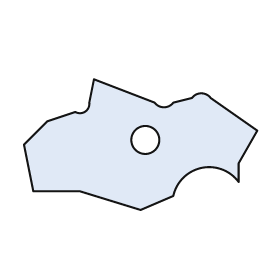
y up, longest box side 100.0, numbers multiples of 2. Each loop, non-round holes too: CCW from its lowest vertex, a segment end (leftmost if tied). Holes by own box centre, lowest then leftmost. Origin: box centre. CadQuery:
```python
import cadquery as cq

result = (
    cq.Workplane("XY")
    .moveTo(0.0, -28.0)
    .lineTo(14.0, -22.0)
    .threePointArc((26.0, -10.0), (42.0, -16.0))
    .lineTo(42.0, -8.0)
    .lineTo(50.0, 6.0)
    .lineTo(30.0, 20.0)
    .threePointArc((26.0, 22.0), (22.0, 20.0))
    .lineTo(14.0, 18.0)
    .threePointArc((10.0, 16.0), (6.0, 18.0))
    .lineTo(-20.0, 28.0)
    .lineTo(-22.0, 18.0)
    .threePointArc((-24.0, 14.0), (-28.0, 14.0))
    .lineTo(-40.0, 10.0)
    .lineTo(-50.0, 0.0)
    .lineTo(-46.0, -20.0)
    .lineTo(-26.0, -20.0)
    .close()
    .moveTo(2.0, 2.0)
    .circle(6.0)
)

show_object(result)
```